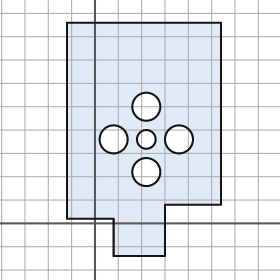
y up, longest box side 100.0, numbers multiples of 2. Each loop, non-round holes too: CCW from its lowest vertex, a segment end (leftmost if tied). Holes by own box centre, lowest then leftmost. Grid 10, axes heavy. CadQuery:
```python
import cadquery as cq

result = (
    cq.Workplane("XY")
    .moveTo(8.0, -14.0)
    .lineTo(30.0, -14.0)
    .lineTo(30.0, 8.0)
    .lineTo(54.0, 8.0)
    .lineTo(54.0, 86.0)
    .lineTo(-12.0, 86.0)
    .lineTo(-12.0, 2.0)
    .lineTo(8.0, 2.0)
    .close()
    .moveTo(22.0, 22.0)
    .circle(6.0)
    .moveTo(8.0, 36.0)
    .circle(6.0)
    .moveTo(22.0, 36.0)
    .circle(4.0)
    .moveTo(36.0, 36.0)
    .circle(6.0)
    .moveTo(22.0, 50.0)
    .circle(6.0)
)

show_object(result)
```